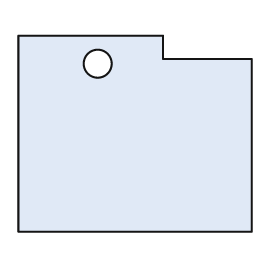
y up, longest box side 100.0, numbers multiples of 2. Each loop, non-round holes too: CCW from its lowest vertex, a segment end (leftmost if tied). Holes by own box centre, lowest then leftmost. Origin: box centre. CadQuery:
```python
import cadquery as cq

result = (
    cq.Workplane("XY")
    .moveTo(-50.0, -42.0)
    .lineTo(50.0, -42.0)
    .lineTo(50.0, 32.0)
    .lineTo(12.0, 32.0)
    .lineTo(12.0, 42.0)
    .lineTo(-50.0, 42.0)
    .close()
    .moveTo(-16.0, 30.0)
    .circle(6.0)
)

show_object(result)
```